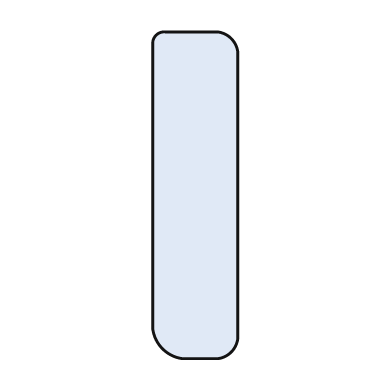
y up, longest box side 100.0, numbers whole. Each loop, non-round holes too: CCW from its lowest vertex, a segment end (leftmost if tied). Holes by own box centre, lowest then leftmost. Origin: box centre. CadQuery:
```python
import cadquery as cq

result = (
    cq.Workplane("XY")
    .moveTo(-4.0, -50.0)
    .lineTo(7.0, -50.0)
    .threePointArc((11.0, -48.0), (13.0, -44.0))
    .lineTo(13.0, 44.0)
    .threePointArc((11.0, 48.0), (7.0, 50.0))
    .lineTo(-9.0, 50.0)
    .threePointArc((-12.0, 49.0), (-13.0, 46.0))
    .lineTo(-13.0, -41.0)
    .threePointArc((-10.0, -47.0), (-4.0, -50.0))
    .close()
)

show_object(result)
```